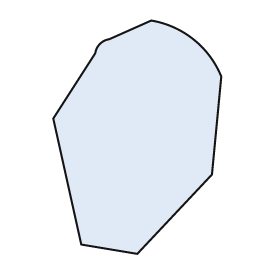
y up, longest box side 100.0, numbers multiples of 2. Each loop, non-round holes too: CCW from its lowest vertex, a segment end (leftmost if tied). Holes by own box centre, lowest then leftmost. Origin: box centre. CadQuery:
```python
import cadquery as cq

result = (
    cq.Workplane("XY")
    .moveTo(0.0, -50.0)
    .lineTo(32.0, -16.0)
    .lineTo(36.0, 26.0)
    .threePointArc((24.0, 42.0), (6.0, 50.0))
    .lineTo(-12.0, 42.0)
    .threePointArc((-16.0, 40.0), (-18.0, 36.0))
    .lineTo(-36.0, 8.0)
    .lineTo(-24.0, -46.0)
    .close()
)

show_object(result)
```